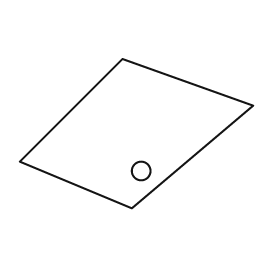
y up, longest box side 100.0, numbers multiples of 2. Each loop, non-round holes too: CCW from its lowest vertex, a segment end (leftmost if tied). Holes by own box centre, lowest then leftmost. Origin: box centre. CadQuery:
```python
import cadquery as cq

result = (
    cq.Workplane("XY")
    .moveTo(-2.0, -32.0)
    .lineTo(50.0, 12.0)
    .lineTo(-6.0, 32.0)
    .lineTo(-50.0, -12.0)
    .close()
    .moveTo(2.0, -16.0)
    .circle(4.0)
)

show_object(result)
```